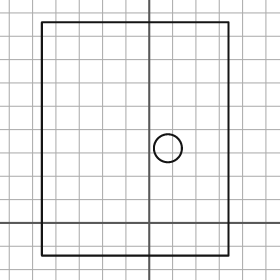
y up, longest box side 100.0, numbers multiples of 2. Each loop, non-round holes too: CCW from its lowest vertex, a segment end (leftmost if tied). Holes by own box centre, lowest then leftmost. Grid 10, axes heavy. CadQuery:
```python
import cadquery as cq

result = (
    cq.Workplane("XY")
    .moveTo(-46.0, -14.0)
    .lineTo(34.0, -14.0)
    .lineTo(34.0, 86.0)
    .lineTo(-46.0, 86.0)
    .close()
    .moveTo(8.0, 32.0)
    .circle(6.0)
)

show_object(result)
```